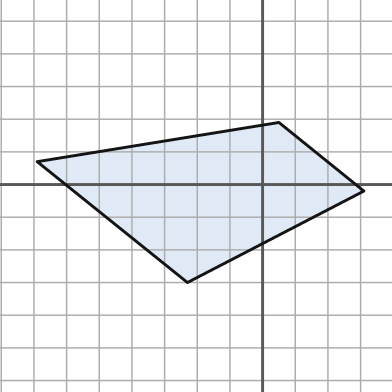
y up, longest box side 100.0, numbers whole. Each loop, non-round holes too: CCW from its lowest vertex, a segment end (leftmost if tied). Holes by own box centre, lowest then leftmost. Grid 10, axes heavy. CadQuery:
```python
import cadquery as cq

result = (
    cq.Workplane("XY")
    .moveTo(-23.0, -30.0)
    .lineTo(31.0, -2.0)
    .lineTo(5.0, 19.0)
    .lineTo(-69.0, 7.0)
    .close()
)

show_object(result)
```